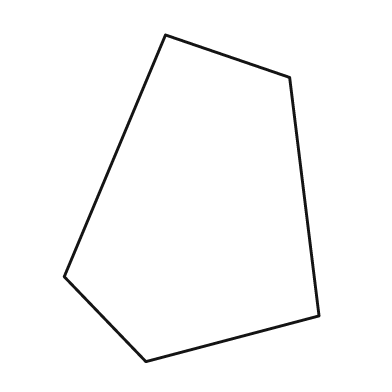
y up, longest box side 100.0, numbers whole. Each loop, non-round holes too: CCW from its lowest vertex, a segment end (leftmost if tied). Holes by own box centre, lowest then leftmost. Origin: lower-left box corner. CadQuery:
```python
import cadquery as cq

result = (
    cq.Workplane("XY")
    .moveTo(25.0, 0.0)
    .lineTo(78.0, 14.0)
    .lineTo(69.0, 87.0)
    .lineTo(31.0, 100.0)
    .lineTo(0.0, 26.0)
    .close()
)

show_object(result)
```